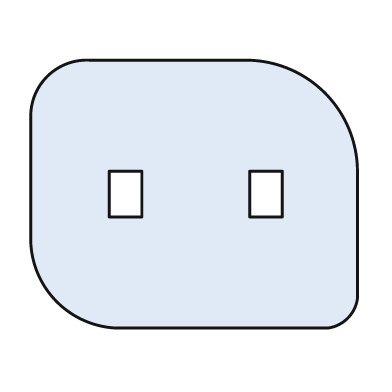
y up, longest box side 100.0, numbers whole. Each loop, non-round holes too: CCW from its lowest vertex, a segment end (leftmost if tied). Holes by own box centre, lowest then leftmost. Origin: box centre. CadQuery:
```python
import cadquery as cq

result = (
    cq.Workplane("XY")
    .moveTo(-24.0, -41.0)
    .lineTo(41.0, -41.0)
    .threePointArc((47.0, -38.0), (50.0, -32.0))
    .lineTo(50.0, 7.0)
    .threePointArc((40.0, 31.0), (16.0, 41.0))
    .lineTo(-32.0, 41.0)
    .threePointArc((-45.0, 36.0), (-50.0, 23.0))
    .lineTo(-50.0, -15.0)
    .threePointArc((-42.0, -33.0), (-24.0, -41.0))
    .close()
    .moveTo(-26.0, -7.0)
    .lineTo(-16.0, -7.0)
    .lineTo(-16.0, 7.0)
    .lineTo(-26.0, 7.0)
    .close()
    .moveTo(17.0, -7.0)
    .lineTo(27.0, -7.0)
    .lineTo(27.0, 7.0)
    .lineTo(17.0, 7.0)
    .close()
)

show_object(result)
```